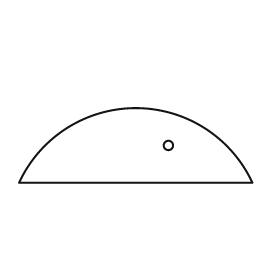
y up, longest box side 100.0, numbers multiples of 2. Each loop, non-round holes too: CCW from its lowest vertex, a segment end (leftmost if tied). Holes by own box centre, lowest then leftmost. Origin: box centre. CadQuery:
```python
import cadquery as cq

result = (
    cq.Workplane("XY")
    .moveTo(-50.0, -16.0)
    .lineTo(50.0, -16.0)
    .threePointArc((0.0, 16.0), (-50.0, -16.0))
    .close()
    .moveTo(14.0, 0.0)
    .circle(2.0)
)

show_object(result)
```